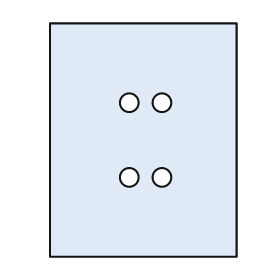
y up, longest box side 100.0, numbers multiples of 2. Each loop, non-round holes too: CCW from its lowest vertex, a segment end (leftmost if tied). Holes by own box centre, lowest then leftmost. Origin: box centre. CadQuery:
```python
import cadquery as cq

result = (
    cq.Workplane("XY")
    .moveTo(-40.0, -50.0)
    .lineTo(40.0, -50.0)
    .lineTo(40.0, 50.0)
    .lineTo(-40.0, 50.0)
    .close()
    .moveTo(-6.0, -16.0)
    .circle(4.0)
    .moveTo(8.0, -16.0)
    .circle(4.0)
    .moveTo(-6.0, 16.0)
    .circle(4.0)
    .moveTo(8.0, 16.0)
    .circle(4.0)
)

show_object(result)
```